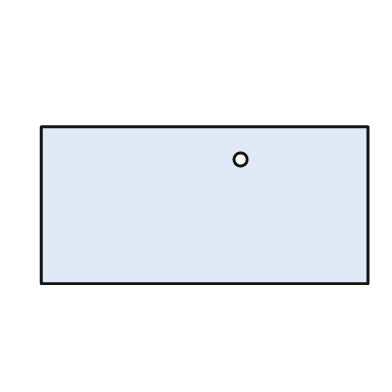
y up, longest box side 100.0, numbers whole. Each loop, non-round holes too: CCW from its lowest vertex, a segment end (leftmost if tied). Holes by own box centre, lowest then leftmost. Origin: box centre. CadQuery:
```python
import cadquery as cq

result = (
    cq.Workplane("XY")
    .moveTo(-50.0, -24.0)
    .lineTo(50.0, -24.0)
    .lineTo(50.0, 24.0)
    .lineTo(-50.0, 24.0)
    .close()
    .moveTo(11.0, 14.0)
    .circle(2.0)
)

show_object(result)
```